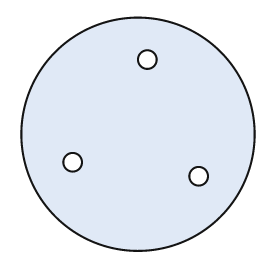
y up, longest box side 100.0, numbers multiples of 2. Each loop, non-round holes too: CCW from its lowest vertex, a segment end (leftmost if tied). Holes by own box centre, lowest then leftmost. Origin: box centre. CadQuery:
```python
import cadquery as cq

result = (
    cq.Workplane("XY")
    .moveTo(0.0, 0.0)
    .circle(50.0)
    .moveTo(26.0, -18.0)
    .circle(4.0)
    .moveTo(-28.0, -12.0)
    .circle(4.0)
    .moveTo(4.0, 32.0)
    .circle(4.0)
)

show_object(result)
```